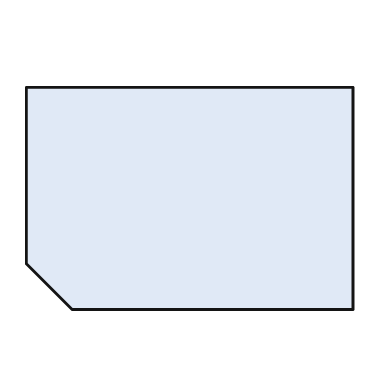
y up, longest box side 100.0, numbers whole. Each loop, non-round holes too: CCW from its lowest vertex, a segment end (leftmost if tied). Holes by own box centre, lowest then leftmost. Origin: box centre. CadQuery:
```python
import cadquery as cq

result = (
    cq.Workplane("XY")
    .moveTo(-36.0, -34.0)
    .lineTo(50.0, -34.0)
    .lineTo(50.0, 34.0)
    .lineTo(-50.0, 34.0)
    .lineTo(-50.0, -20.0)
    .close()
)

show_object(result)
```